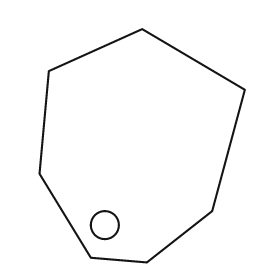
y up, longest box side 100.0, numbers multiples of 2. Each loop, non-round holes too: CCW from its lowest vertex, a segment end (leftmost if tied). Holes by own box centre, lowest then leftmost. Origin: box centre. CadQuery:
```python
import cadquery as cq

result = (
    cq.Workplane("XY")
    .moveTo(2.0, -50.0)
    .lineTo(30.0, -28.0)
    .lineTo(44.0, 24.0)
    .lineTo(0.0, 50.0)
    .lineTo(-40.0, 32.0)
    .lineTo(-44.0, -12.0)
    .lineTo(-22.0, -48.0)
    .close()
    .moveTo(-16.0, -34.0)
    .circle(6.0)
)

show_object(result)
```